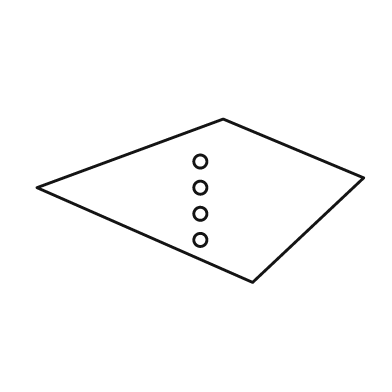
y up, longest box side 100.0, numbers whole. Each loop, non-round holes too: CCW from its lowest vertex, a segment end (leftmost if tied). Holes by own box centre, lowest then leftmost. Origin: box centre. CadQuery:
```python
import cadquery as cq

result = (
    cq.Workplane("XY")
    .moveTo(16.0, -25.0)
    .lineTo(50.0, 7.0)
    .lineTo(7.0, 25.0)
    .lineTo(-50.0, 4.0)
    .close()
    .moveTo(0.0, -12.0)
    .circle(2.0)
    .moveTo(0.0, -4.0)
    .circle(2.0)
    .moveTo(0.0, 4.0)
    .circle(2.0)
    .moveTo(0.0, 12.0)
    .circle(2.0)
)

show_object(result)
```